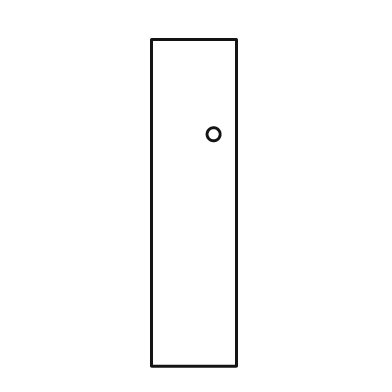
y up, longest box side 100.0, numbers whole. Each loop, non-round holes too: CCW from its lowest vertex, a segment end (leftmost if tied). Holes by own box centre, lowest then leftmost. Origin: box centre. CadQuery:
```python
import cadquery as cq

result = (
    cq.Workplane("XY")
    .moveTo(-13.0, -50.0)
    .lineTo(13.0, -50.0)
    .lineTo(13.0, 50.0)
    .lineTo(-13.0, 50.0)
    .close()
    .moveTo(6.0, 21.0)
    .circle(2.0)
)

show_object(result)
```